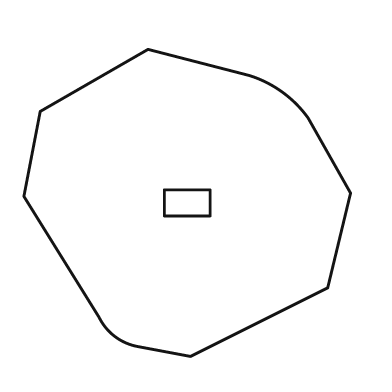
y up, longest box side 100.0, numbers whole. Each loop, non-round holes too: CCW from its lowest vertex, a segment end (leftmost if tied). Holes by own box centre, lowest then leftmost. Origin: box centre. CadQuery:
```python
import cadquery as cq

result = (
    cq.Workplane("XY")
    .moveTo(1.0, -47.0)
    .lineTo(43.0, -26.0)
    .lineTo(50.0, 3.0)
    .lineTo(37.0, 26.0)
    .threePointArc((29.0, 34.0), (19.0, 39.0))
    .lineTo(-12.0, 47.0)
    .lineTo(-45.0, 28.0)
    .lineTo(-50.0, 2.0)
    .lineTo(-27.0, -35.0)
    .threePointArc((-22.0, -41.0), (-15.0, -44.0))
    .close()
    .moveTo(-7.0, -4.0)
    .lineTo(7.0, -4.0)
    .lineTo(7.0, 4.0)
    .lineTo(-7.0, 4.0)
    .close()
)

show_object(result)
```